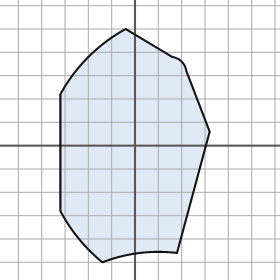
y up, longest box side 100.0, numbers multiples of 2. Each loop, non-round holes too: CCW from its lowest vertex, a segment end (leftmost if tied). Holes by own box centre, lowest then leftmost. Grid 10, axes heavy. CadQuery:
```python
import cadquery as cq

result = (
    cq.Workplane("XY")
    .moveTo(-14.0, -50.0)
    .threePointArc((2.0, -46.0), (18.0, -46.0))
    .lineTo(32.0, 6.0)
    .lineTo(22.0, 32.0)
    .threePointArc((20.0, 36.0), (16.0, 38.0))
    .lineTo(-4.0, 50.0)
    .threePointArc((-20.0, 38.0), (-32.0, 22.0))
    .lineTo(-32.0, -28.0)
    .threePointArc((-24.0, -40.0), (-14.0, -50.0))
    .close()
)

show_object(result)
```